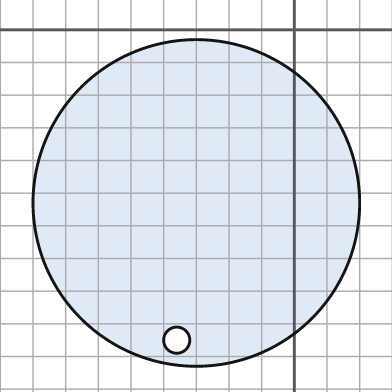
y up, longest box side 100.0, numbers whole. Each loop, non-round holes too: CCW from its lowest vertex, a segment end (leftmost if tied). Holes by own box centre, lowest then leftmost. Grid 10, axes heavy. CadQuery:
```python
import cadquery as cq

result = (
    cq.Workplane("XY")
    .moveTo(-30.0, -53.0)
    .circle(50.0)
    .moveTo(-36.0, -95.0)
    .circle(4.0)
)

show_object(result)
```